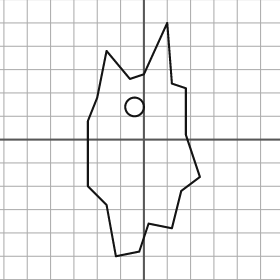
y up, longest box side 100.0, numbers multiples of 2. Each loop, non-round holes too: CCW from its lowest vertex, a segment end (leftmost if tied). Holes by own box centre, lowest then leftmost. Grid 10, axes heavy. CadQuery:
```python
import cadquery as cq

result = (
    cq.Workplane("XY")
    .moveTo(-12.0, -50.0)
    .lineTo(-2.0, -48.0)
    .lineTo(2.0, -36.0)
    .lineTo(12.0, -38.0)
    .lineTo(16.0, -22.0)
    .lineTo(24.0, -16.0)
    .lineTo(18.0, 2.0)
    .lineTo(18.0, 22.0)
    .lineTo(12.0, 24.0)
    .lineTo(10.0, 50.0)
    .lineTo(0.0, 28.0)
    .lineTo(-6.0, 26.0)
    .lineTo(-16.0, 38.0)
    .lineTo(-20.0, 18.0)
    .lineTo(-24.0, 8.0)
    .lineTo(-24.0, -20.0)
    .lineTo(-16.0, -28.0)
    .close()
    .moveTo(-4.0, 14.0)
    .circle(4.0)
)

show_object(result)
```